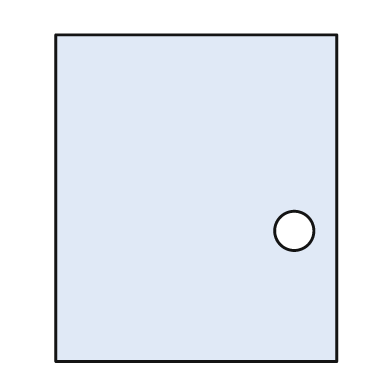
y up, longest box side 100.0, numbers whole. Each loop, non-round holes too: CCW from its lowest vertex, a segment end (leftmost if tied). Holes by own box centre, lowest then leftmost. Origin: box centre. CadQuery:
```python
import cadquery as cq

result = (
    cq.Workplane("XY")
    .moveTo(-43.0, -50.0)
    .lineTo(43.0, -50.0)
    .lineTo(43.0, 50.0)
    .lineTo(-43.0, 50.0)
    .close()
    .moveTo(30.0, -10.0)
    .circle(6.0)
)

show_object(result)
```